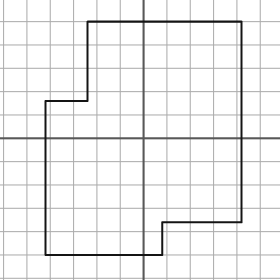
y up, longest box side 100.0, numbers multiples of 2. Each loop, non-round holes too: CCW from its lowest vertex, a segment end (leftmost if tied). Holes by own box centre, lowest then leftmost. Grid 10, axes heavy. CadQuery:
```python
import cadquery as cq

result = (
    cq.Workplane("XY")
    .moveTo(-42.0, -50.0)
    .lineTo(8.0, -50.0)
    .lineTo(8.0, -36.0)
    .lineTo(42.0, -36.0)
    .lineTo(42.0, 50.0)
    .lineTo(-24.0, 50.0)
    .lineTo(-24.0, 16.0)
    .lineTo(-42.0, 16.0)
    .close()
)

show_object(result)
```